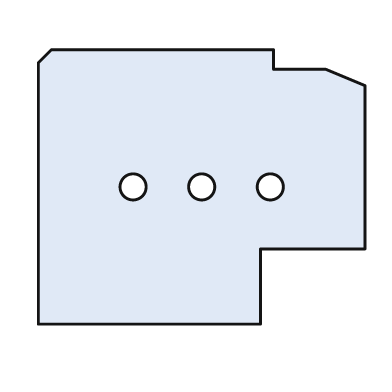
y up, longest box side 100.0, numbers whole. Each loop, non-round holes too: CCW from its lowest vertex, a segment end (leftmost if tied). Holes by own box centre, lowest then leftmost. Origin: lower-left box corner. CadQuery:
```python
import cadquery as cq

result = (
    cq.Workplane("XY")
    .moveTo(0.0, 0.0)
    .lineTo(68.0, 0.0)
    .lineTo(68.0, 23.0)
    .lineTo(100.0, 23.0)
    .lineTo(100.0, 73.0)
    .lineTo(88.0, 78.0)
    .lineTo(72.0, 78.0)
    .lineTo(72.0, 84.0)
    .lineTo(4.0, 84.0)
    .lineTo(0.0, 80.0)
    .close()
    .moveTo(29.0, 42.0)
    .circle(4.0)
    .moveTo(50.0, 42.0)
    .circle(4.0)
    .moveTo(71.0, 42.0)
    .circle(4.0)
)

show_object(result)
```